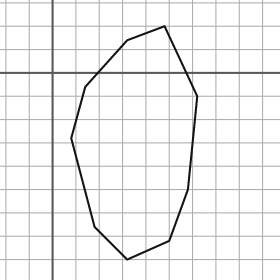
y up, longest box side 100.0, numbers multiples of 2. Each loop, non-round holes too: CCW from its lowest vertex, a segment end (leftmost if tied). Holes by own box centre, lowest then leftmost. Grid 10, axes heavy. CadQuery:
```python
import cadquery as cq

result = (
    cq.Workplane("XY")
    .moveTo(32.0, -80.0)
    .lineTo(50.0, -72.0)
    .lineTo(58.0, -50.0)
    .lineTo(62.0, -10.0)
    .lineTo(48.0, 20.0)
    .lineTo(32.0, 14.0)
    .lineTo(14.0, -6.0)
    .lineTo(8.0, -28.0)
    .lineTo(18.0, -66.0)
    .close()
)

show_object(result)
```